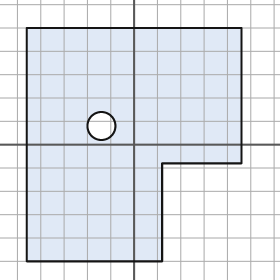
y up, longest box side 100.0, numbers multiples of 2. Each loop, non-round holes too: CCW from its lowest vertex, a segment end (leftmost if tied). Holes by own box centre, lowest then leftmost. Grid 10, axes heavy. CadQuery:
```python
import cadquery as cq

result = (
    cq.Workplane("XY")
    .moveTo(-46.0, -50.0)
    .lineTo(12.0, -50.0)
    .lineTo(12.0, -8.0)
    .lineTo(46.0, -8.0)
    .lineTo(46.0, 50.0)
    .lineTo(-46.0, 50.0)
    .close()
    .moveTo(-14.0, 8.0)
    .circle(6.0)
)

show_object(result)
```